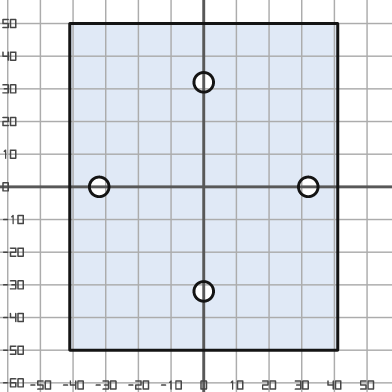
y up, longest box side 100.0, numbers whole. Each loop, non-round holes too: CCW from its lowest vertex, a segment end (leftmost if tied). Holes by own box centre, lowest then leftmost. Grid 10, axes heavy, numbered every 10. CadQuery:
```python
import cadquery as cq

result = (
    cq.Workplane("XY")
    .moveTo(-41.0, -50.0)
    .lineTo(41.0, -50.0)
    .lineTo(41.0, 50.0)
    .lineTo(-41.0, 50.0)
    .close()
    .moveTo(0.0, -32.0)
    .circle(3.0)
    .moveTo(-32.0, 0.0)
    .circle(3.0)
    .moveTo(32.0, 0.0)
    .circle(3.0)
    .moveTo(0.0, 32.0)
    .circle(3.0)
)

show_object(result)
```